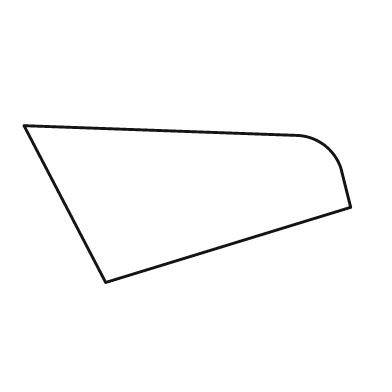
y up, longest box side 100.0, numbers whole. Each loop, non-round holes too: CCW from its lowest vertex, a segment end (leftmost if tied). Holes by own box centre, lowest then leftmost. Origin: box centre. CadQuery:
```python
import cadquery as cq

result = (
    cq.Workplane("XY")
    .moveTo(-25.0, -24.0)
    .lineTo(50.0, -1.0)
    .lineTo(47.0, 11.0)
    .threePointArc((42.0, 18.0), (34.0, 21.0))
    .lineTo(-50.0, 24.0)
    .close()
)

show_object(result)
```